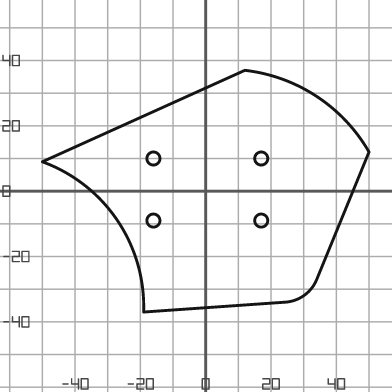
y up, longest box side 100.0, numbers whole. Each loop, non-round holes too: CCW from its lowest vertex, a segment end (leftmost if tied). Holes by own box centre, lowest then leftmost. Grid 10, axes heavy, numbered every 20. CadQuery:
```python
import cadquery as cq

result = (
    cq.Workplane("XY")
    .moveTo(-19.0, -37.0)
    .lineTo(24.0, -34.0)
    .threePointArc((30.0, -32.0), (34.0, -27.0))
    .lineTo(50.0, 12.0)
    .threePointArc((34.0, 29.0), (12.0, 37.0))
    .lineTo(-50.0, 9.0)
    .threePointArc((-27.0, -9.0), (-19.0, -37.0))
    .close()
    .moveTo(-16.0, -9.0)
    .circle(2.0)
    .moveTo(17.0, -9.0)
    .circle(2.0)
    .moveTo(-16.0, 10.0)
    .circle(2.0)
    .moveTo(17.0, 10.0)
    .circle(2.0)
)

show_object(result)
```